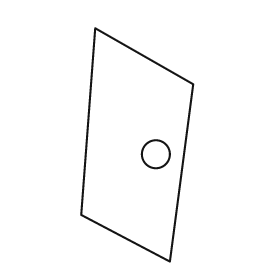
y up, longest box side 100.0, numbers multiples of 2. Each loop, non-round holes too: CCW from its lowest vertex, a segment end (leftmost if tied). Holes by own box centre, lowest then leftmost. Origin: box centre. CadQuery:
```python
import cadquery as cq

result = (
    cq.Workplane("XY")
    .moveTo(14.0, -50.0)
    .lineTo(24.0, 26.0)
    .lineTo(-18.0, 50.0)
    .lineTo(-24.0, -30.0)
    .close()
    .moveTo(8.0, -4.0)
    .circle(6.0)
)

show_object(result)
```